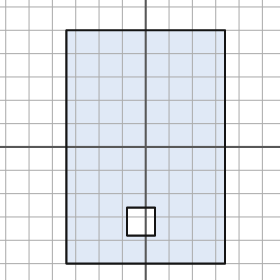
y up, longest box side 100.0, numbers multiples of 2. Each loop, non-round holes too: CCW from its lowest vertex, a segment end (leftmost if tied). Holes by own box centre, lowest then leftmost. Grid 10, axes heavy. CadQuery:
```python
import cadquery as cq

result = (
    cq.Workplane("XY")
    .moveTo(-34.0, -50.0)
    .lineTo(34.0, -50.0)
    .lineTo(34.0, 50.0)
    .lineTo(-34.0, 50.0)
    .close()
    .moveTo(-8.0, -38.0)
    .lineTo(4.0, -38.0)
    .lineTo(4.0, -26.0)
    .lineTo(-8.0, -26.0)
    .close()
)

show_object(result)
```